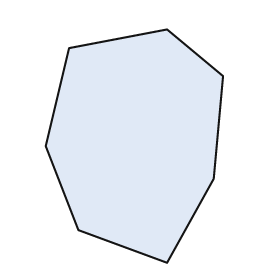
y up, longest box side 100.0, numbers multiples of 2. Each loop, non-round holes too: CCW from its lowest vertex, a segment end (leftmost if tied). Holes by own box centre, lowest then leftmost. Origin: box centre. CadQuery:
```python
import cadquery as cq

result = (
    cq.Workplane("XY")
    .moveTo(14.0, -50.0)
    .lineTo(34.0, -14.0)
    .lineTo(38.0, 30.0)
    .lineTo(14.0, 50.0)
    .lineTo(-28.0, 42.0)
    .lineTo(-38.0, 0.0)
    .lineTo(-24.0, -36.0)
    .close()
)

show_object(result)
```